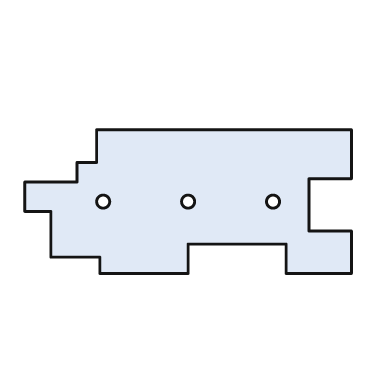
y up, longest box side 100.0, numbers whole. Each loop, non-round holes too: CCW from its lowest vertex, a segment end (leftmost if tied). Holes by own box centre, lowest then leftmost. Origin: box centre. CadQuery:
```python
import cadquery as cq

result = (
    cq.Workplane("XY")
    .moveTo(-27.0, -22.0)
    .lineTo(0.0, -22.0)
    .lineTo(0.0, -13.0)
    .lineTo(30.0, -13.0)
    .lineTo(30.0, -22.0)
    .lineTo(50.0, -22.0)
    .lineTo(50.0, -9.0)
    .lineTo(37.0, -9.0)
    .lineTo(37.0, 7.0)
    .lineTo(50.0, 7.0)
    .lineTo(50.0, 22.0)
    .lineTo(-28.0, 22.0)
    .lineTo(-28.0, 12.0)
    .lineTo(-34.0, 12.0)
    .lineTo(-34.0, 6.0)
    .lineTo(-50.0, 6.0)
    .lineTo(-50.0, -3.0)
    .lineTo(-42.0, -3.0)
    .lineTo(-42.0, -17.0)
    .lineTo(-27.0, -17.0)
    .close()
    .moveTo(-26.0, 0.0)
    .circle(2.0)
    .moveTo(0.0, 0.0)
    .circle(2.0)
    .moveTo(26.0, 0.0)
    .circle(2.0)
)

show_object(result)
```